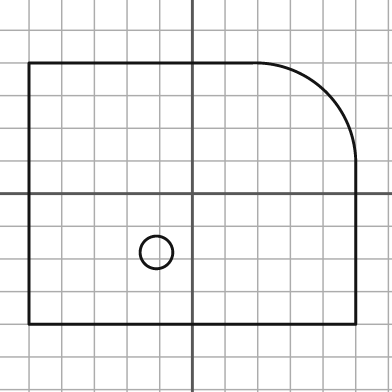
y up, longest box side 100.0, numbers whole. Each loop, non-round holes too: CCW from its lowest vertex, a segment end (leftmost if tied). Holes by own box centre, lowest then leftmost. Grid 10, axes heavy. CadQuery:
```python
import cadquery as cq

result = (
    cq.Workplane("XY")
    .moveTo(-50.0, -40.0)
    .lineTo(50.0, -40.0)
    .lineTo(50.0, 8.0)
    .threePointArc((41.0, 31.0), (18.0, 40.0))
    .lineTo(-50.0, 40.0)
    .close()
    .moveTo(-11.0, -18.0)
    .circle(5.0)
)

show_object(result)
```